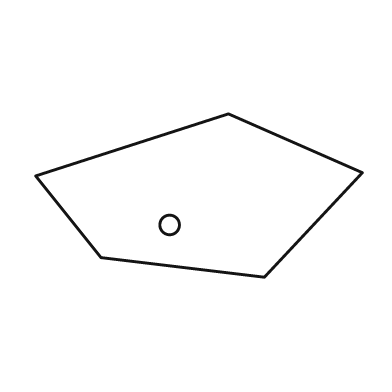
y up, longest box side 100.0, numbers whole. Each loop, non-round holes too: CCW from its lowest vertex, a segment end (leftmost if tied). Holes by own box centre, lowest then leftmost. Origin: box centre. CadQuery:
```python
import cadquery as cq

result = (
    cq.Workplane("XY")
    .moveTo(20.0, -25.0)
    .lineTo(50.0, 7.0)
    .lineTo(9.0, 25.0)
    .lineTo(-50.0, 6.0)
    .lineTo(-30.0, -19.0)
    .close()
    .moveTo(-9.0, -9.0)
    .circle(3.0)
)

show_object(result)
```